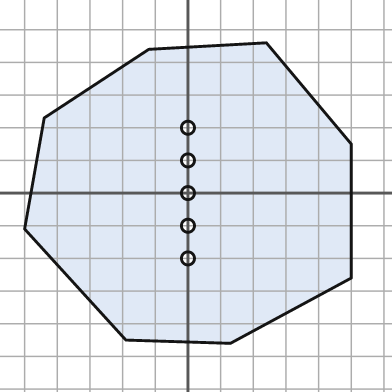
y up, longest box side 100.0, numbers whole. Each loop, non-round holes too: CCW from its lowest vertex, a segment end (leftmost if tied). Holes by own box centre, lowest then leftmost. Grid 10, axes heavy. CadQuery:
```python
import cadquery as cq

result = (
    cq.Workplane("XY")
    .moveTo(13.0, -46.0)
    .lineTo(50.0, -26.0)
    .lineTo(50.0, 15.0)
    .lineTo(24.0, 46.0)
    .lineTo(-12.0, 44.0)
    .lineTo(-44.0, 23.0)
    .lineTo(-50.0, -11.0)
    .lineTo(-19.0, -45.0)
    .close()
    .moveTo(0.0, -20.0)
    .circle(2.0)
    .moveTo(0.0, -10.0)
    .circle(2.0)
    .moveTo(0.0, 0.0)
    .circle(2.0)
    .moveTo(0.0, 10.0)
    .circle(2.0)
    .moveTo(0.0, 20.0)
    .circle(2.0)
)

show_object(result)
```